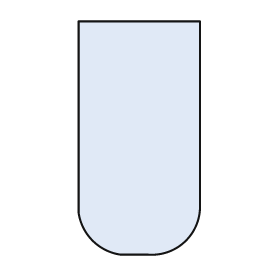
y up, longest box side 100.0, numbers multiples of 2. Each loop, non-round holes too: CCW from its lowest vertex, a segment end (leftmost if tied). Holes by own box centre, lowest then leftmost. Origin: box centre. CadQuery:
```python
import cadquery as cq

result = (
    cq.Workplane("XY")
    .moveTo(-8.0, -50.0)
    .lineTo(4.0, -50.0)
    .threePointArc((20.0, -44.0), (26.0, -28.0))
    .lineTo(26.0, 50.0)
    .lineTo(-26.0, 50.0)
    .lineTo(-26.0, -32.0)
    .threePointArc((-20.0, -44.0), (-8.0, -50.0))
    .close()
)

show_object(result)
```